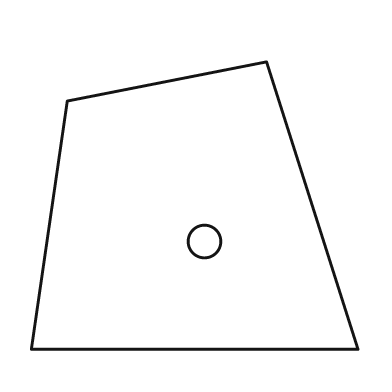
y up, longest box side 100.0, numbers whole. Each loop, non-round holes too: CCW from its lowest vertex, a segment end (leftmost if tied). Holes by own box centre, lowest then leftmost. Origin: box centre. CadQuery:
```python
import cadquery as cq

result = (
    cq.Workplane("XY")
    .moveTo(-50.0, -44.0)
    .lineTo(50.0, -44.0)
    .lineTo(22.0, 44.0)
    .lineTo(-39.0, 32.0)
    .close()
    .moveTo(3.0, -11.0)
    .circle(5.0)
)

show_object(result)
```